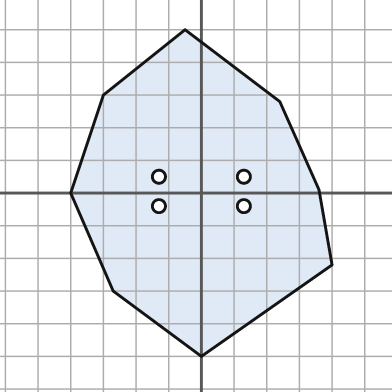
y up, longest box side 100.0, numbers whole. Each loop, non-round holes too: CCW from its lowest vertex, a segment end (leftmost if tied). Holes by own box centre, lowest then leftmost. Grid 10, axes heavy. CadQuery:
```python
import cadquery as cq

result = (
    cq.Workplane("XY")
    .moveTo(0.0, -50.0)
    .lineTo(40.0, -22.0)
    .lineTo(36.0, 1.0)
    .lineTo(24.0, 28.0)
    .lineTo(-5.0, 50.0)
    .lineTo(-30.0, 30.0)
    .lineTo(-40.0, 0.0)
    .lineTo(-27.0, -30.0)
    .close()
    .moveTo(-13.0, -4.0)
    .circle(2.0)
    .moveTo(13.0, -4.0)
    .circle(2.0)
    .moveTo(-13.0, 5.0)
    .circle(2.0)
    .moveTo(13.0, 5.0)
    .circle(2.0)
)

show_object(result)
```